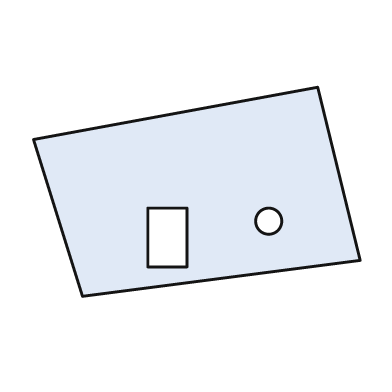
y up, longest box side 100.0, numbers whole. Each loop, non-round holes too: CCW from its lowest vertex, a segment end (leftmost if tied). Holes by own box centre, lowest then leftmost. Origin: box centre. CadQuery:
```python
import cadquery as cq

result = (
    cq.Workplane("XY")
    .moveTo(-35.0, -32.0)
    .lineTo(50.0, -21.0)
    .lineTo(37.0, 32.0)
    .lineTo(-50.0, 16.0)
    .close()
    .moveTo(-15.0, -23.0)
    .lineTo(-3.0, -23.0)
    .lineTo(-3.0, -5.0)
    .lineTo(-15.0, -5.0)
    .close()
    .moveTo(22.0, -9.0)
    .circle(4.0)
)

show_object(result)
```